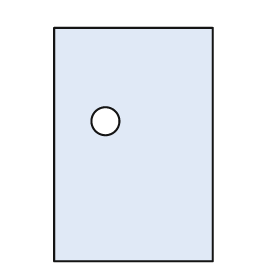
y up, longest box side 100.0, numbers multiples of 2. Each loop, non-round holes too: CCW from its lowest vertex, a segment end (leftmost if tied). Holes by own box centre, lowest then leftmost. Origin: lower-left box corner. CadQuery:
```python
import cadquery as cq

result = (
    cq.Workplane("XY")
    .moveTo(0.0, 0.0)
    .lineTo(68.0, 0.0)
    .lineTo(68.0, 100.0)
    .lineTo(0.0, 100.0)
    .close()
    .moveTo(22.0, 60.0)
    .circle(6.0)
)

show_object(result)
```